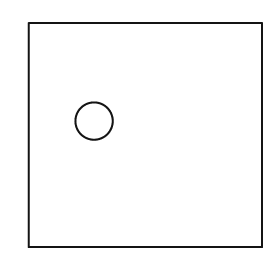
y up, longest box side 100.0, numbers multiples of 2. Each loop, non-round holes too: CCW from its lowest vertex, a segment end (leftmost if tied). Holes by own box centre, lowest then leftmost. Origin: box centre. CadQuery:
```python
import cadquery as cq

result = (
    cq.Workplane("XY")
    .moveTo(-50.0, -48.0)
    .lineTo(50.0, -48.0)
    .lineTo(50.0, 48.0)
    .lineTo(-50.0, 48.0)
    .close()
    .moveTo(-22.0, 6.0)
    .circle(8.0)
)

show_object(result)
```